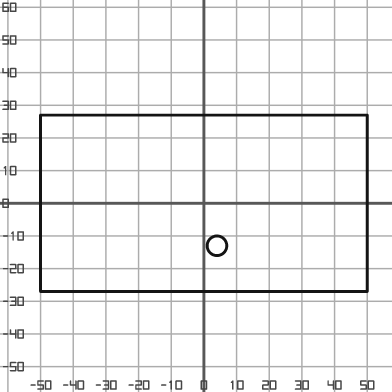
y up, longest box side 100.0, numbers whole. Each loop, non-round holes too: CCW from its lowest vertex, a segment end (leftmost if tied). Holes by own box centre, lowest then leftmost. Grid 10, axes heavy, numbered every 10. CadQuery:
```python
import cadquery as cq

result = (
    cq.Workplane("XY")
    .moveTo(-50.0, -27.0)
    .lineTo(50.0, -27.0)
    .lineTo(50.0, 27.0)
    .lineTo(-50.0, 27.0)
    .close()
    .moveTo(4.0, -13.0)
    .circle(3.0)
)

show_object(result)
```